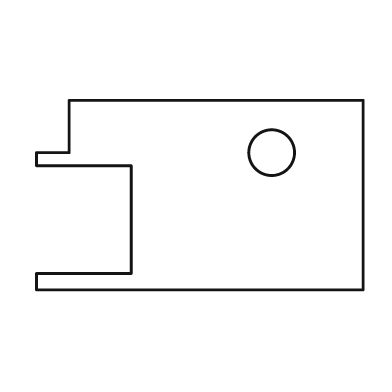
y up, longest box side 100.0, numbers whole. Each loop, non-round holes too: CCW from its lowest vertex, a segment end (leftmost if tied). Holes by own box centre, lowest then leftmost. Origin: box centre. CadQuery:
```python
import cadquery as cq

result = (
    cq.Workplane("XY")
    .moveTo(-50.0, -29.0)
    .lineTo(50.0, -29.0)
    .lineTo(50.0, 29.0)
    .lineTo(-40.0, 29.0)
    .lineTo(-40.0, 13.0)
    .lineTo(-50.0, 13.0)
    .lineTo(-50.0, 9.0)
    .lineTo(-21.0, 9.0)
    .lineTo(-21.0, -24.0)
    .lineTo(-50.0, -24.0)
    .close()
    .moveTo(22.0, 13.0)
    .circle(7.0)
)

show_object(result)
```